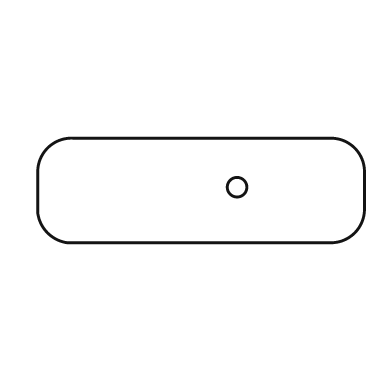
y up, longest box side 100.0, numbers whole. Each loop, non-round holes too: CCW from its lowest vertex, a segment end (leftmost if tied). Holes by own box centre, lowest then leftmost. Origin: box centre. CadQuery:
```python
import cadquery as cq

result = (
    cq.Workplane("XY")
    .moveTo(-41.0, -16.0)
    .lineTo(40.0, -16.0)
    .threePointArc((47.0, -13.0), (50.0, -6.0))
    .lineTo(50.0, 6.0)
    .threePointArc((47.0, 13.0), (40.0, 16.0))
    .lineTo(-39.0, 16.0)
    .threePointArc((-47.0, 13.0), (-50.0, 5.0))
    .lineTo(-50.0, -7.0)
    .threePointArc((-47.0, -13.0), (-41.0, -16.0))
    .close()
    .moveTo(11.0, 1.0)
    .circle(3.0)
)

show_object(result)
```